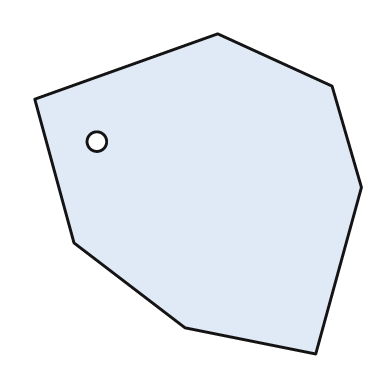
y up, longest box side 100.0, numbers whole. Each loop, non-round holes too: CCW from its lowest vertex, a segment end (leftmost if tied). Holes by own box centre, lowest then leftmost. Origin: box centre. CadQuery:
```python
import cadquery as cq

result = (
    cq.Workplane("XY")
    .moveTo(36.0, -49.0)
    .lineTo(50.0, 2.0)
    .lineTo(41.0, 33.0)
    .lineTo(6.0, 49.0)
    .lineTo(-50.0, 29.0)
    .lineTo(-38.0, -15.0)
    .lineTo(-4.0, -41.0)
    .close()
    .moveTo(-31.0, 16.0)
    .circle(3.0)
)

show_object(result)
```